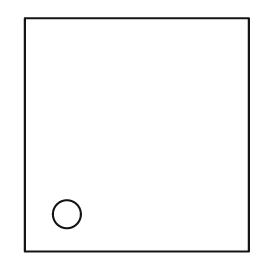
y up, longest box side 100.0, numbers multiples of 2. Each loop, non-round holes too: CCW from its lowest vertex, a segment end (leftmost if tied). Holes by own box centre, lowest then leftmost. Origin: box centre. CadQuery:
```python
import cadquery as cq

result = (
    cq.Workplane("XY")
    .moveTo(-48.0, -50.0)
    .lineTo(48.0, -50.0)
    .lineTo(48.0, 50.0)
    .lineTo(-48.0, 50.0)
    .close()
    .moveTo(-30.0, -34.0)
    .circle(6.0)
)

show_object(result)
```